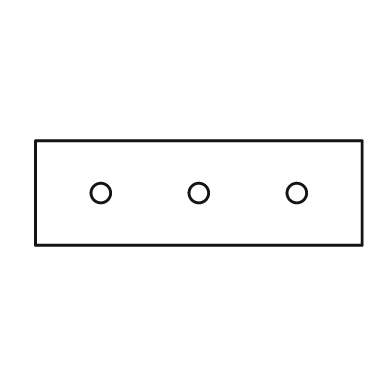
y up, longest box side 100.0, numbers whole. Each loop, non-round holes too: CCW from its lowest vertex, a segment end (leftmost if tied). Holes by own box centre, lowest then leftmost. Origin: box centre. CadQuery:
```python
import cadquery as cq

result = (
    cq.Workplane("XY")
    .moveTo(-50.0, -16.0)
    .lineTo(50.0, -16.0)
    .lineTo(50.0, 16.0)
    .lineTo(-50.0, 16.0)
    .close()
    .moveTo(-30.0, 0.0)
    .circle(3.0)
    .moveTo(0.0, 0.0)
    .circle(3.0)
    .moveTo(30.0, 0.0)
    .circle(3.0)
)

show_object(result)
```